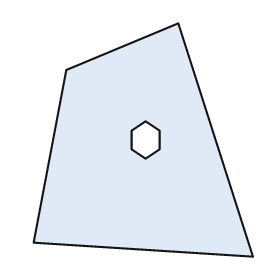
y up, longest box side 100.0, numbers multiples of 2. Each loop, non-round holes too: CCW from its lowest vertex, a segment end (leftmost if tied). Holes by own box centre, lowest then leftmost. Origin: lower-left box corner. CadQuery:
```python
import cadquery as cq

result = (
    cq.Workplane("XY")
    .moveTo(94.0, 0.0)
    .lineTo(62.0, 100.0)
    .lineTo(14.0, 80.0)
    .lineTo(0.0, 6.0)
    .close()
    .moveTo(48.0, 42.0)
    .lineTo(54.0, 46.0)
    .lineTo(54.0, 54.0)
    .lineTo(48.0, 58.0)
    .lineTo(42.0, 54.0)
    .lineTo(42.0, 46.0)
    .close()
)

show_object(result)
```